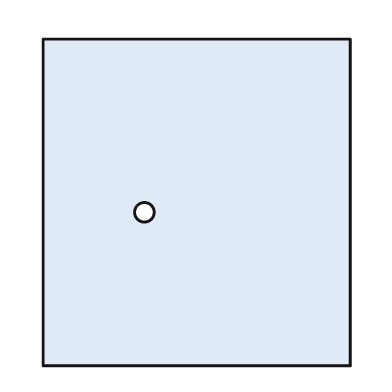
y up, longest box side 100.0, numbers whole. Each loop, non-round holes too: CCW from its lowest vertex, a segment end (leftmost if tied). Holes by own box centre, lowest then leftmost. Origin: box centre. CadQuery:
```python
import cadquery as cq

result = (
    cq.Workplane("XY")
    .moveTo(-47.0, -50.0)
    .lineTo(47.0, -50.0)
    .lineTo(47.0, 50.0)
    .lineTo(-47.0, 50.0)
    .close()
    .moveTo(-16.0, -3.0)
    .circle(3.0)
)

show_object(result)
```